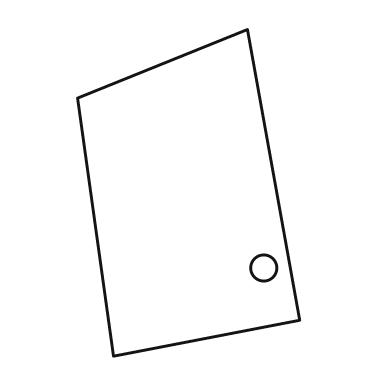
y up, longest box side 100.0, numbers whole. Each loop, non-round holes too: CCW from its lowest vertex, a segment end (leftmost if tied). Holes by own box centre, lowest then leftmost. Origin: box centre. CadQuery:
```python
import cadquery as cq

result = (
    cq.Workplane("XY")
    .moveTo(-23.0, -50.0)
    .lineTo(34.0, -39.0)
    .lineTo(18.0, 50.0)
    .lineTo(-34.0, 29.0)
    .close()
    .moveTo(23.0, -23.0)
    .circle(4.0)
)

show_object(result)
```